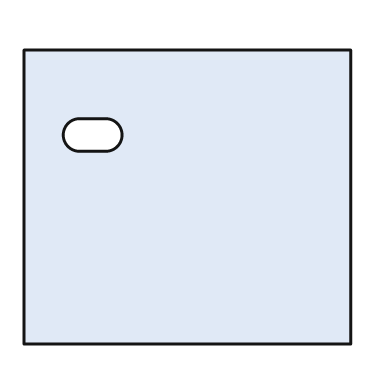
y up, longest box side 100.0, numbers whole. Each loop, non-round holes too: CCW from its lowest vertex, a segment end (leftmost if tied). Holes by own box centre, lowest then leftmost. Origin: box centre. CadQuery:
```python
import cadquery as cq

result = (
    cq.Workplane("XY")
    .moveTo(-50.0, -45.0)
    .lineTo(50.0, -45.0)
    .lineTo(50.0, 45.0)
    .lineTo(-50.0, 45.0)
    .close()
    .moveTo(-33.0, 14.0)
    .lineTo(-25.0, 14.0)
    .threePointArc((-20.0, 19.0), (-25.0, 24.0))
    .lineTo(-33.0, 24.0)
    .threePointArc((-38.0, 19.0), (-33.0, 14.0))
    .close()
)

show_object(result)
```